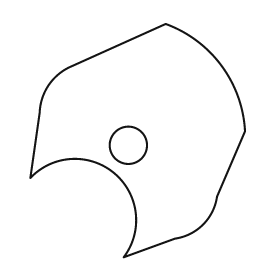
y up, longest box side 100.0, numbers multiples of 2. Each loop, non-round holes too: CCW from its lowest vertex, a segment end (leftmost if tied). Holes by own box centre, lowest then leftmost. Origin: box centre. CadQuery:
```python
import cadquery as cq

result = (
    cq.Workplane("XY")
    .moveTo(-6.0, -50.0)
    .lineTo(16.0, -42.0)
    .threePointArc((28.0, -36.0), (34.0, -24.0))
    .lineTo(46.0, 4.0)
    .threePointArc((36.0, 32.0), (12.0, 50.0))
    .lineTo(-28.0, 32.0)
    .threePointArc((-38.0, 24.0), (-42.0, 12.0))
    .lineTo(-46.0, -16.0)
    .threePointArc((-10.0, -14.0), (-6.0, -50.0))
    .close()
    .moveTo(-4.0, -2.0)
    .circle(8.0)
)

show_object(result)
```